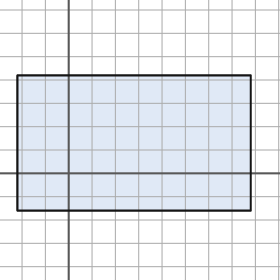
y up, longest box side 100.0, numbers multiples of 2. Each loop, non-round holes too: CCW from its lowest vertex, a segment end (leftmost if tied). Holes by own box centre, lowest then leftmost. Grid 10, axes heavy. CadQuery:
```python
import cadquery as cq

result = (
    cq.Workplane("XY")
    .moveTo(-22.0, -16.0)
    .lineTo(78.0, -16.0)
    .lineTo(78.0, 42.0)
    .lineTo(-22.0, 42.0)
    .close()
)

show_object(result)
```